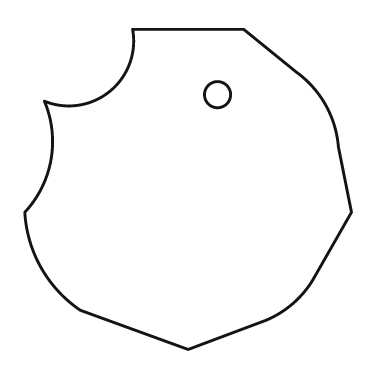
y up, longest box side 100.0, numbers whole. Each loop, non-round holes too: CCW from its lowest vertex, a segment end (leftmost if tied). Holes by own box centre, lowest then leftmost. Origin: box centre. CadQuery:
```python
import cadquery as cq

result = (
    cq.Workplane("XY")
    .moveTo(0.0, -49.0)
    .lineTo(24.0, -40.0)
    .threePointArc((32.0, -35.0), (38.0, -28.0))
    .lineTo(50.0, -7.0)
    .lineTo(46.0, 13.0)
    .threePointArc((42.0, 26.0), (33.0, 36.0))
    .lineTo(17.0, 49.0)
    .lineTo(-17.0, 49.0)
    .threePointArc((-24.0, 30.0), (-44.0, 27.0))
    .threePointArc((-42.0, 9.0), (-50.0, -7.0))
    .threePointArc((-45.0, -24.0), (-33.0, -37.0))
    .close()
    .moveTo(9.0, 29.0)
    .circle(4.0)
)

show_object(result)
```